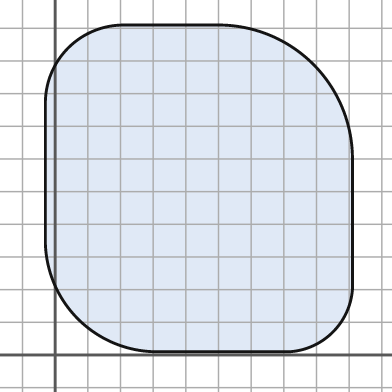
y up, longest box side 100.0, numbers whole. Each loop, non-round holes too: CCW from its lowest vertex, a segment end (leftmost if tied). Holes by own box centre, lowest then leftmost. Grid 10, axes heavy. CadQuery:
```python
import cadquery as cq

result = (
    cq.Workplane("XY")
    .moveTo(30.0, 1.0)
    .lineTo(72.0, 1.0)
    .threePointArc((85.0, 7.0), (91.0, 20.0))
    .lineTo(91.0, 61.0)
    .threePointArc((79.0, 89.0), (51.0, 101.0))
    .lineTo(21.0, 101.0)
    .threePointArc((4.0, 94.0), (-3.0, 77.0))
    .lineTo(-3.0, 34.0)
    .threePointArc((7.0, 11.0), (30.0, 1.0))
    .close()
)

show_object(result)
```